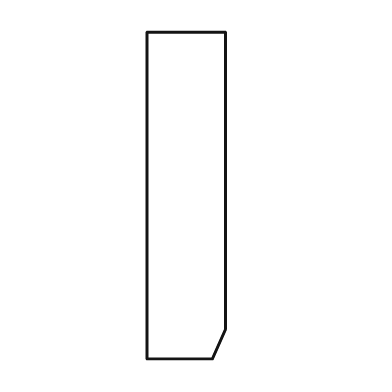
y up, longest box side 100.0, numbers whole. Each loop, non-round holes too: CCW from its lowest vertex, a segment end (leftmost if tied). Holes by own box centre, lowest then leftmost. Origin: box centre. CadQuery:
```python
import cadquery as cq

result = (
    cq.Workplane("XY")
    .moveTo(-12.0, -50.0)
    .lineTo(8.0, -50.0)
    .lineTo(12.0, -41.0)
    .lineTo(12.0, 50.0)
    .lineTo(-12.0, 50.0)
    .close()
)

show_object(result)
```